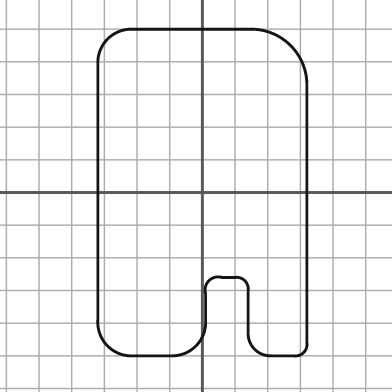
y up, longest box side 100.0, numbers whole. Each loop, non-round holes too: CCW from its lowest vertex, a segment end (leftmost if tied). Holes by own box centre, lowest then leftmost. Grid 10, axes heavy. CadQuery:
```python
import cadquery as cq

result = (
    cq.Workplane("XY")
    .moveTo(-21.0, -50.0)
    .lineTo(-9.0, -50.0)
    .threePointArc((-2.0, -47.0), (1.0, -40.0))
    .lineTo(1.0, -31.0)
    .threePointArc((2.0, -27.0), (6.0, -26.0))
    .lineTo(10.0, -26.0)
    .threePointArc((13.0, -27.0), (14.0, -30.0))
    .lineTo(14.0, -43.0)
    .threePointArc((16.0, -48.0), (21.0, -50.0))
    .lineTo(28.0, -50.0)
    .threePointArc((31.0, -49.0), (32.0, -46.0))
    .lineTo(32.0, 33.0)
    .threePointArc((27.0, 45.0), (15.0, 50.0))
    .lineTo(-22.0, 50.0)
    .threePointArc((-29.0, 47.0), (-32.0, 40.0))
    .lineTo(-32.0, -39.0)
    .threePointArc((-29.0, -47.0), (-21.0, -50.0))
    .close()
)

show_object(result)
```